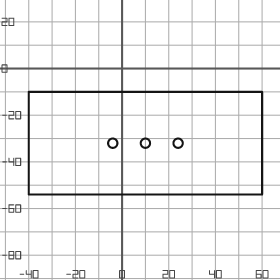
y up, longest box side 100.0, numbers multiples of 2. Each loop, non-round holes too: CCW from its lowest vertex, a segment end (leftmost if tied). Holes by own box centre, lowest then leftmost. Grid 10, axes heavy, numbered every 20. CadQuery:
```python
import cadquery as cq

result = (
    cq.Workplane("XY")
    .moveTo(-40.0, -54.0)
    .lineTo(60.0, -54.0)
    .lineTo(60.0, -10.0)
    .lineTo(-40.0, -10.0)
    .close()
    .moveTo(-4.0, -32.0)
    .circle(2.0)
    .moveTo(10.0, -32.0)
    .circle(2.0)
    .moveTo(24.0, -32.0)
    .circle(2.0)
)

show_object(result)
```